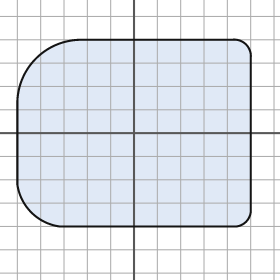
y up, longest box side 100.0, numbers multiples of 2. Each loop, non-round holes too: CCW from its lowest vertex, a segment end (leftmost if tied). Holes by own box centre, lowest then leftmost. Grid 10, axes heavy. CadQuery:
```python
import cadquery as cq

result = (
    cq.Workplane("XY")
    .moveTo(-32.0, -40.0)
    .lineTo(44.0, -40.0)
    .threePointArc((48.0, -38.0), (50.0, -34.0))
    .lineTo(50.0, 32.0)
    .threePointArc((48.0, 38.0), (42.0, 40.0))
    .lineTo(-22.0, 40.0)
    .threePointArc((-42.0, 32.0), (-50.0, 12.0))
    .lineTo(-50.0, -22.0)
    .threePointArc((-44.0, -34.0), (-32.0, -40.0))
    .close()
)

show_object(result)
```